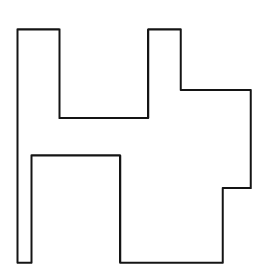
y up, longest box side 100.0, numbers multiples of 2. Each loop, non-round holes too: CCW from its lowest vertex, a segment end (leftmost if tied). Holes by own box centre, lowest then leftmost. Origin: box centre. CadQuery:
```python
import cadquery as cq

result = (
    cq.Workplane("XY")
    .moveTo(-50.0, -50.0)
    .lineTo(-44.0, -50.0)
    .lineTo(-44.0, -4.0)
    .lineTo(-6.0, -4.0)
    .lineTo(-6.0, -50.0)
    .lineTo(38.0, -50.0)
    .lineTo(38.0, -18.0)
    .lineTo(50.0, -18.0)
    .lineTo(50.0, 24.0)
    .lineTo(20.0, 24.0)
    .lineTo(20.0, 50.0)
    .lineTo(6.0, 50.0)
    .lineTo(6.0, 12.0)
    .lineTo(-32.0, 12.0)
    .lineTo(-32.0, 50.0)
    .lineTo(-50.0, 50.0)
    .close()
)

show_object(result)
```